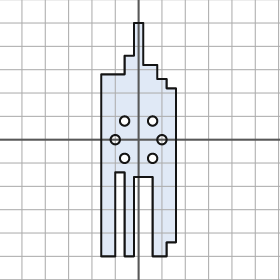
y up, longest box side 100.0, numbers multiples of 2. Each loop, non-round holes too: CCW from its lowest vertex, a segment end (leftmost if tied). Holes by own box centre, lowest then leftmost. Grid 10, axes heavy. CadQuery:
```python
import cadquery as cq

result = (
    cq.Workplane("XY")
    .moveTo(-16.0, -50.0)
    .lineTo(-10.0, -50.0)
    .lineTo(-10.0, -14.0)
    .lineTo(-6.0, -14.0)
    .lineTo(-6.0, -50.0)
    .lineTo(-2.0, -50.0)
    .lineTo(-2.0, -16.0)
    .lineTo(6.0, -16.0)
    .lineTo(6.0, -50.0)
    .lineTo(12.0, -50.0)
    .lineTo(12.0, -44.0)
    .lineTo(16.0, -44.0)
    .lineTo(16.0, 22.0)
    .lineTo(12.0, 22.0)
    .lineTo(12.0, 26.0)
    .lineTo(8.0, 26.0)
    .lineTo(8.0, 32.0)
    .lineTo(2.0, 32.0)
    .lineTo(2.0, 50.0)
    .lineTo(-2.0, 50.0)
    .lineTo(-2.0, 36.0)
    .lineTo(-6.0, 36.0)
    .lineTo(-6.0, 28.0)
    .lineTo(-16.0, 28.0)
    .close()
    .moveTo(-6.0, -8.0)
    .circle(2.0)
    .moveTo(6.0, -8.0)
    .circle(2.0)
    .moveTo(-10.0, 0.0)
    .circle(2.0)
    .moveTo(10.0, 0.0)
    .circle(2.0)
    .moveTo(-6.0, 8.0)
    .circle(2.0)
    .moveTo(6.0, 8.0)
    .circle(2.0)
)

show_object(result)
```